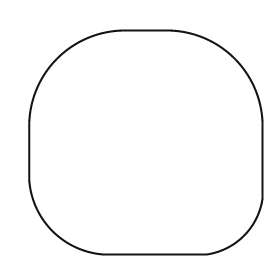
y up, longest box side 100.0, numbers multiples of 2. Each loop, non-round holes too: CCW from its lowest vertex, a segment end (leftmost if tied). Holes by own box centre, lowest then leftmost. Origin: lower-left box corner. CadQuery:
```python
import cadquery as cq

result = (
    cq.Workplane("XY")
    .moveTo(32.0, 0.0)
    .lineTo(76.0, 0.0)
    .threePointArc((92.0, 8.0), (100.0, 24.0))
    .lineTo(100.0, 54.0)
    .threePointArc((88.0, 84.0), (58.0, 96.0))
    .lineTo(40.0, 96.0)
    .threePointArc((12.0, 84.0), (0.0, 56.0))
    .lineTo(0.0, 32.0)
    .threePointArc((10.0, 10.0), (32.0, 0.0))
    .close()
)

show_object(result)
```